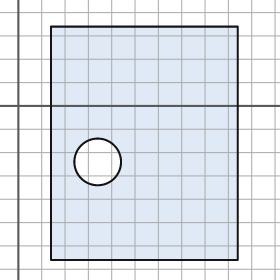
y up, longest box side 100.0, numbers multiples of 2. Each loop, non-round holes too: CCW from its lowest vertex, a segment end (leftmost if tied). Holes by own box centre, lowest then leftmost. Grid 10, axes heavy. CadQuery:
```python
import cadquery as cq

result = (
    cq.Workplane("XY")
    .moveTo(14.0, -66.0)
    .lineTo(94.0, -66.0)
    .lineTo(94.0, 34.0)
    .lineTo(14.0, 34.0)
    .close()
    .moveTo(34.0, -24.0)
    .circle(10.0)
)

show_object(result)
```